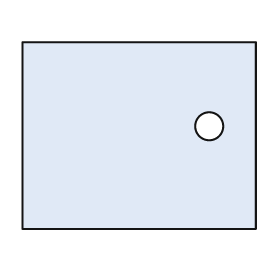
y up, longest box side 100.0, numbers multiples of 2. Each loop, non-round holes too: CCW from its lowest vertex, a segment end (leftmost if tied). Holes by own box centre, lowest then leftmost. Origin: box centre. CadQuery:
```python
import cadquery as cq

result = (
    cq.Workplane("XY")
    .moveTo(-50.0, -40.0)
    .lineTo(50.0, -40.0)
    .lineTo(50.0, 40.0)
    .lineTo(-50.0, 40.0)
    .close()
    .moveTo(30.0, 4.0)
    .circle(6.0)
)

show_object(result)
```